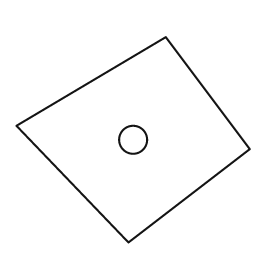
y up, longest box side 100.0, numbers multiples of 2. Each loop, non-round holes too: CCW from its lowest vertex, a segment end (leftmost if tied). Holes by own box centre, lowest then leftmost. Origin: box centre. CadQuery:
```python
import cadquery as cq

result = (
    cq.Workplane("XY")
    .moveTo(-2.0, -44.0)
    .lineTo(50.0, -4.0)
    .lineTo(14.0, 44.0)
    .lineTo(-50.0, 6.0)
    .close()
    .moveTo(0.0, 0.0)
    .circle(6.0)
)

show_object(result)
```